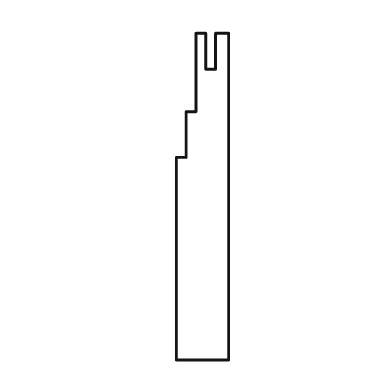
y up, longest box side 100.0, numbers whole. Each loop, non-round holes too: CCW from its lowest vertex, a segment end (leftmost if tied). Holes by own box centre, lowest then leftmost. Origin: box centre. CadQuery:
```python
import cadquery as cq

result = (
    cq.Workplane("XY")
    .moveTo(-8.0, -50.0)
    .lineTo(8.0, -50.0)
    .lineTo(8.0, 50.0)
    .lineTo(4.0, 50.0)
    .lineTo(4.0, 39.0)
    .lineTo(1.0, 39.0)
    .lineTo(1.0, 50.0)
    .lineTo(-2.0, 50.0)
    .lineTo(-2.0, 26.0)
    .lineTo(-5.0, 26.0)
    .lineTo(-5.0, 12.0)
    .lineTo(-8.0, 12.0)
    .close()
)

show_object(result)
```